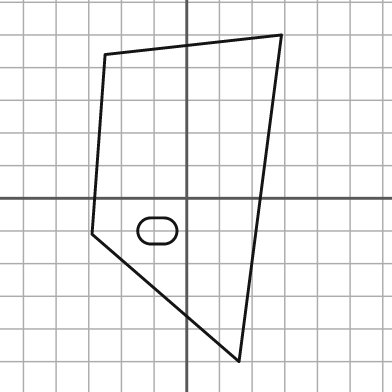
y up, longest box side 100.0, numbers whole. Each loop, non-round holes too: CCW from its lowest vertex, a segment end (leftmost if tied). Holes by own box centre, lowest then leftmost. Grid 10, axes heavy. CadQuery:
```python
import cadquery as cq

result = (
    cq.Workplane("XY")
    .moveTo(16.0, -50.0)
    .lineTo(29.0, 50.0)
    .lineTo(-25.0, 44.0)
    .lineTo(-29.0, -11.0)
    .close()
    .moveTo(-11.0, -14.0)
    .lineTo(-7.0, -14.0)
    .threePointArc((-3.0, -10.0), (-7.0, -6.0))
    .lineTo(-11.0, -6.0)
    .threePointArc((-15.0, -10.0), (-11.0, -14.0))
    .close()
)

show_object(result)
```